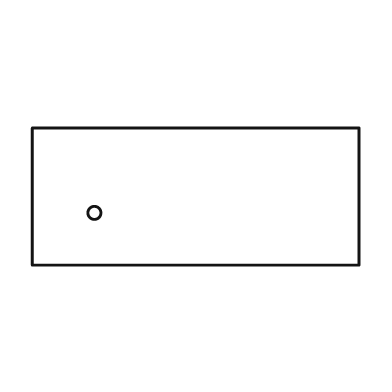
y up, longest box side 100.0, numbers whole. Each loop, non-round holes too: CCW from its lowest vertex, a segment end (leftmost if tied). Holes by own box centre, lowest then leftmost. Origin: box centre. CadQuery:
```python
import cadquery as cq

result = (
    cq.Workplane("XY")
    .moveTo(-50.0, -21.0)
    .lineTo(50.0, -21.0)
    .lineTo(50.0, 21.0)
    .lineTo(-50.0, 21.0)
    .close()
    .moveTo(-31.0, -5.0)
    .circle(2.0)
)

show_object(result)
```